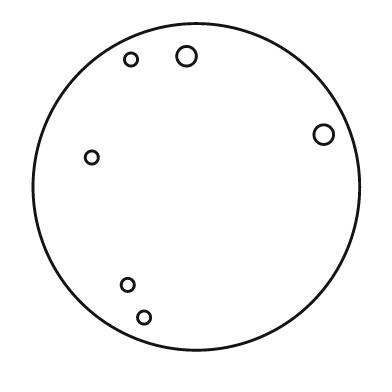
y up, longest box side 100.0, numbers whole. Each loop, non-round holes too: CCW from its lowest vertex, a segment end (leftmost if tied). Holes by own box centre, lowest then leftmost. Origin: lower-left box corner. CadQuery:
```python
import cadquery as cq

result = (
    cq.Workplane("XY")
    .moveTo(50.0, 50.0)
    .circle(50.0)
    .moveTo(34.0, 10.0)
    .circle(2.0)
    .moveTo(29.0, 20.0)
    .circle(2.0)
    .moveTo(18.0, 59.0)
    .circle(2.0)
    .moveTo(89.0, 66.0)
    .circle(3.0)
    .moveTo(30.0, 89.0)
    .circle(2.0)
    .moveTo(47.0, 90.0)
    .circle(3.0)
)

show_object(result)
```